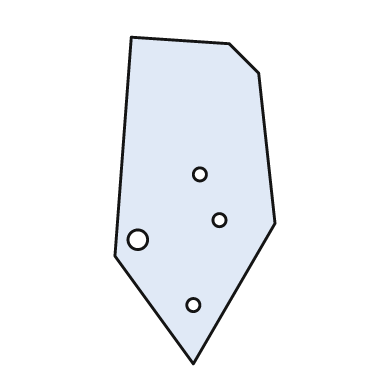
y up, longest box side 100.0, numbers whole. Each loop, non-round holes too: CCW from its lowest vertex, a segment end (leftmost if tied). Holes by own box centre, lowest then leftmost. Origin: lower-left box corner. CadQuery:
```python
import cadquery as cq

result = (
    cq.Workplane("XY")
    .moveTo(24.0, 0.0)
    .lineTo(49.0, 43.0)
    .lineTo(44.0, 89.0)
    .lineTo(35.0, 98.0)
    .lineTo(5.0, 100.0)
    .lineTo(0.0, 33.0)
    .close()
    .moveTo(24.0, 18.0)
    .circle(2.0)
    .moveTo(7.0, 38.0)
    .circle(3.0)
    .moveTo(32.0, 44.0)
    .circle(2.0)
    .moveTo(26.0, 58.0)
    .circle(2.0)
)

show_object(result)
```